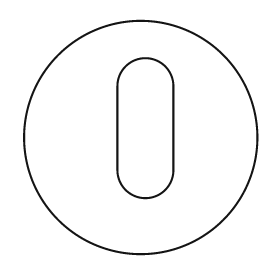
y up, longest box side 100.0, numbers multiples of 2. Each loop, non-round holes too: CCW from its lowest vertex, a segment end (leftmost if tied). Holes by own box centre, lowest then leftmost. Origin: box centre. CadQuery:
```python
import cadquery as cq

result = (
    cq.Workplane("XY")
    .moveTo(0.0, 0.0)
    .circle(50.0)
    .moveTo(-10.0, -14.0)
    .threePointArc((2.0, -26.0), (14.0, -14.0))
    .lineTo(14.0, 22.0)
    .threePointArc((2.0, 34.0), (-10.0, 22.0))
    .close()
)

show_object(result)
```